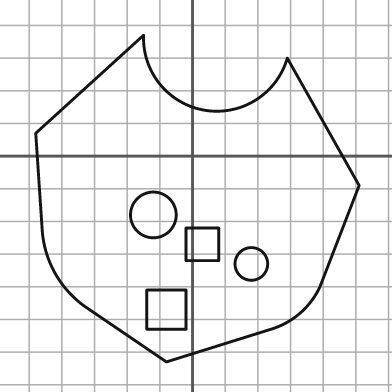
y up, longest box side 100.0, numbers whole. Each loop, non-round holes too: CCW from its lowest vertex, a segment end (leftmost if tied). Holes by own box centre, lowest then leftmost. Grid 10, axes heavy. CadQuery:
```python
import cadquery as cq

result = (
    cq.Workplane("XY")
    .moveTo(-8.0, -63.0)
    .lineTo(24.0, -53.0)
    .threePointArc((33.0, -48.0), (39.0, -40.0))
    .lineTo(51.0, -9.0)
    .lineTo(29.0, 30.0)
    .threePointArc((4.0, 14.0), (-15.0, 37.0))
    .lineTo(-48.0, 7.0)
    .lineTo(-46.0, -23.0)
    .threePointArc((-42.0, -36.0), (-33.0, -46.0))
    .close()
    .moveTo(-14.0, -53.0)
    .lineTo(-2.0, -53.0)
    .lineTo(-2.0, -41.0)
    .lineTo(-14.0, -41.0)
    .close()
    .moveTo(18.0, -33.0)
    .circle(5.0)
    .moveTo(-2.0, -32.0)
    .lineTo(8.0, -32.0)
    .lineTo(8.0, -22.0)
    .lineTo(-2.0, -22.0)
    .close()
    .moveTo(-12.0, -18.0)
    .circle(7.0)
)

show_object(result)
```